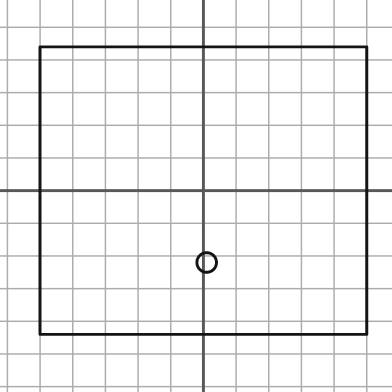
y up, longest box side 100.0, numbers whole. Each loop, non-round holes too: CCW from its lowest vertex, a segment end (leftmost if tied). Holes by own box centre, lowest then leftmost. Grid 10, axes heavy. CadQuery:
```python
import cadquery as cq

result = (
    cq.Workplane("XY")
    .moveTo(-50.0, -44.0)
    .lineTo(50.0, -44.0)
    .lineTo(50.0, 44.0)
    .lineTo(-50.0, 44.0)
    .close()
    .moveTo(1.0, -22.0)
    .circle(3.0)
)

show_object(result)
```